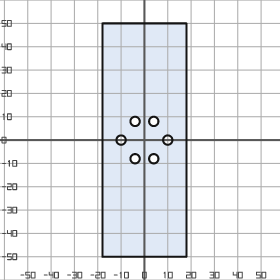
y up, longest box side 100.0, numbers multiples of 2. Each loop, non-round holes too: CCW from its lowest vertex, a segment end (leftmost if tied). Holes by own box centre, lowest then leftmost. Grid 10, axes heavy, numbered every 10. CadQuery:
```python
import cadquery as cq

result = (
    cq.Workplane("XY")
    .moveTo(-18.0, -50.0)
    .lineTo(18.0, -50.0)
    .lineTo(18.0, 50.0)
    .lineTo(-18.0, 50.0)
    .close()
    .moveTo(-4.0, -8.0)
    .circle(2.0)
    .moveTo(4.0, -8.0)
    .circle(2.0)
    .moveTo(-10.0, 0.0)
    .circle(2.0)
    .moveTo(10.0, 0.0)
    .circle(2.0)
    .moveTo(-4.0, 8.0)
    .circle(2.0)
    .moveTo(4.0, 8.0)
    .circle(2.0)
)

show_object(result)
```